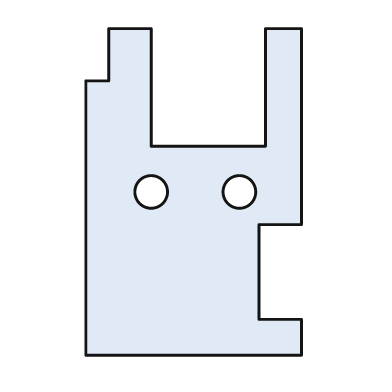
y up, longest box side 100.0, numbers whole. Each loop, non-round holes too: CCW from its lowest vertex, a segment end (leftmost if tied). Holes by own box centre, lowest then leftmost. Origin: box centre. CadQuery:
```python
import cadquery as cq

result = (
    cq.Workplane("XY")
    .moveTo(-33.0, -50.0)
    .lineTo(33.0, -50.0)
    .lineTo(33.0, -39.0)
    .lineTo(20.0, -39.0)
    .lineTo(20.0, -10.0)
    .lineTo(33.0, -10.0)
    .lineTo(33.0, 50.0)
    .lineTo(22.0, 50.0)
    .lineTo(22.0, 14.0)
    .lineTo(-13.0, 14.0)
    .lineTo(-13.0, 50.0)
    .lineTo(-26.0, 50.0)
    .lineTo(-26.0, 34.0)
    .lineTo(-33.0, 34.0)
    .close()
    .moveTo(-13.0, 0.0)
    .circle(5.0)
    .moveTo(14.0, 0.0)
    .circle(5.0)
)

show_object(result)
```